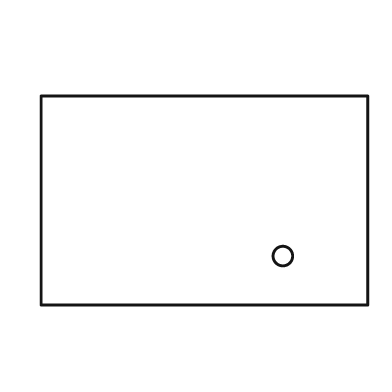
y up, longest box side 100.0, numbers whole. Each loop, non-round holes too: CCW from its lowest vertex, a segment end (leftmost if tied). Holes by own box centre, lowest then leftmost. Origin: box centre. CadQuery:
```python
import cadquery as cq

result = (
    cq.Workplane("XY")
    .moveTo(-50.0, -32.0)
    .lineTo(50.0, -32.0)
    .lineTo(50.0, 32.0)
    .lineTo(-50.0, 32.0)
    .close()
    .moveTo(24.0, -17.0)
    .circle(3.0)
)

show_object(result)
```